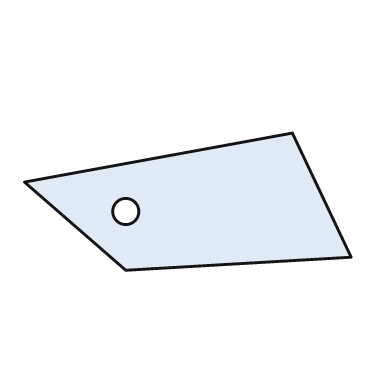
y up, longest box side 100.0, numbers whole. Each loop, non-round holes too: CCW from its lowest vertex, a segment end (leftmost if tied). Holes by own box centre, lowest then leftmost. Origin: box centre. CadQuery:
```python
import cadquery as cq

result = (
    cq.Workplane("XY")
    .moveTo(-19.0, -21.0)
    .lineTo(50.0, -17.0)
    .lineTo(32.0, 21.0)
    .lineTo(-50.0, 6.0)
    .close()
    .moveTo(-19.0, -3.0)
    .circle(4.0)
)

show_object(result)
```